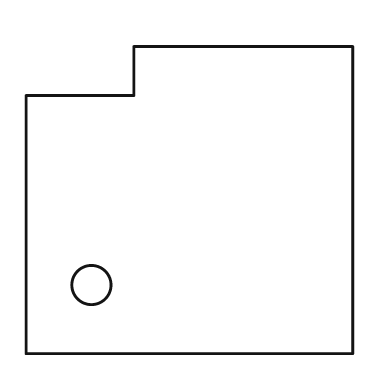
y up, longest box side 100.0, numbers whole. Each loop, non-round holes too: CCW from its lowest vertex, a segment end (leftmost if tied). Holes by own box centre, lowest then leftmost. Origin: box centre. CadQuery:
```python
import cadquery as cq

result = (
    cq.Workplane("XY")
    .moveTo(-50.0, -47.0)
    .lineTo(50.0, -47.0)
    .lineTo(50.0, 47.0)
    .lineTo(-17.0, 47.0)
    .lineTo(-17.0, 32.0)
    .lineTo(-50.0, 32.0)
    .close()
    .moveTo(-30.0, -26.0)
    .circle(6.0)
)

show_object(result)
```